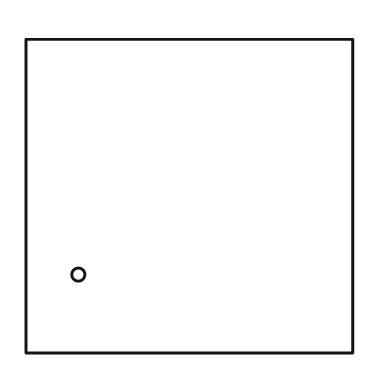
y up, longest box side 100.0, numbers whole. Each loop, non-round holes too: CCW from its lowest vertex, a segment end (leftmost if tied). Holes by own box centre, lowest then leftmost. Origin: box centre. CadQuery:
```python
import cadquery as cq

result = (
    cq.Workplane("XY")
    .moveTo(-50.0, -48.0)
    .lineTo(50.0, -48.0)
    .lineTo(50.0, 48.0)
    .lineTo(-50.0, 48.0)
    .close()
    .moveTo(-34.0, -24.0)
    .circle(2.0)
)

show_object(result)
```